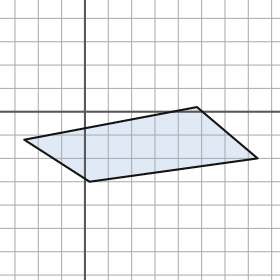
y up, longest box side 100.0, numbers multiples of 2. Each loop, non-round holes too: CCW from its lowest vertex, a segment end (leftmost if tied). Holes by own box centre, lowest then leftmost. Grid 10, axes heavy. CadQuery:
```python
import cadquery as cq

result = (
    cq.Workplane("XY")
    .moveTo(2.0, -30.0)
    .lineTo(74.0, -20.0)
    .lineTo(48.0, 2.0)
    .lineTo(-26.0, -12.0)
    .close()
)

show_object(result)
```